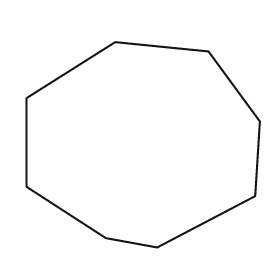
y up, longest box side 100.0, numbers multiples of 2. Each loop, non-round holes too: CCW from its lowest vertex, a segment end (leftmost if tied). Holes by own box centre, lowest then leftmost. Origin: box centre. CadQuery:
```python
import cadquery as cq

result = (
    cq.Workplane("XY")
    .moveTo(6.0, -44.0)
    .lineTo(48.0, -22.0)
    .lineTo(50.0, 10.0)
    .lineTo(28.0, 40.0)
    .lineTo(-12.0, 44.0)
    .lineTo(-50.0, 20.0)
    .lineTo(-50.0, -18.0)
    .lineTo(-16.0, -40.0)
    .close()
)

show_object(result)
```